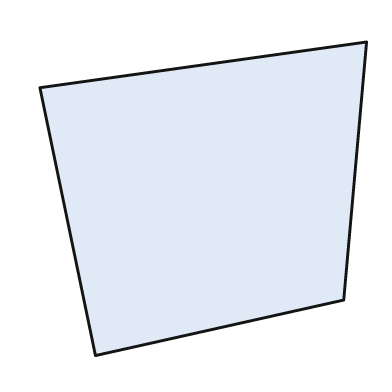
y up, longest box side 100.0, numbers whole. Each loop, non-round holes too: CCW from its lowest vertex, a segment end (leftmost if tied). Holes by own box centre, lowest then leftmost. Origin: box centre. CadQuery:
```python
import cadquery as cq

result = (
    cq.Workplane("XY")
    .moveTo(-33.0, -48.0)
    .lineTo(43.0, -31.0)
    .lineTo(50.0, 48.0)
    .lineTo(-50.0, 34.0)
    .close()
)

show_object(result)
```